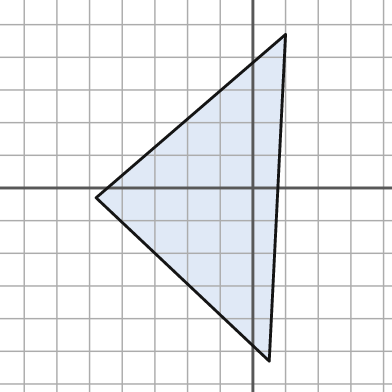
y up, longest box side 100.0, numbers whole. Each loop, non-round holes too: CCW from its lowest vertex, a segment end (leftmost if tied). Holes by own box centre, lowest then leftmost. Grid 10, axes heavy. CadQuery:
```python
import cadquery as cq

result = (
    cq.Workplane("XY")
    .moveTo(5.0, -53.0)
    .lineTo(10.0, 47.0)
    .lineTo(-48.0, -3.0)
    .close()
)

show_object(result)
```